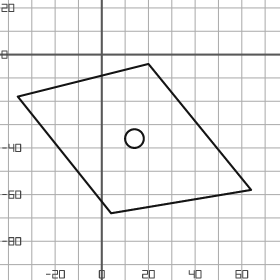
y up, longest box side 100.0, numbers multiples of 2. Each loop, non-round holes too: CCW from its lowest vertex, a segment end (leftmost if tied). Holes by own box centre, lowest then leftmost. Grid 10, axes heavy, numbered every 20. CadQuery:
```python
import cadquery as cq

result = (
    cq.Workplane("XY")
    .moveTo(4.0, -68.0)
    .lineTo(64.0, -58.0)
    .lineTo(20.0, -4.0)
    .lineTo(-36.0, -18.0)
    .close()
    .moveTo(14.0, -36.0)
    .circle(4.0)
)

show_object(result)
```